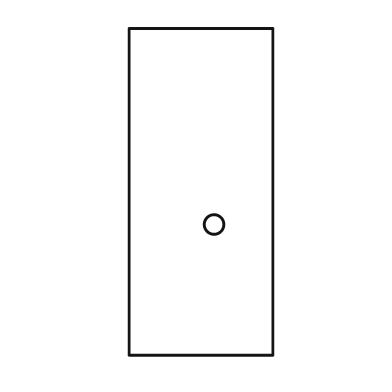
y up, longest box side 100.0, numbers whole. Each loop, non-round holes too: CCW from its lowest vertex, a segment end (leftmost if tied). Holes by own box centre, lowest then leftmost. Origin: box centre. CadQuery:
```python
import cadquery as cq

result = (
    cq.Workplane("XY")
    .moveTo(-22.0, -50.0)
    .lineTo(22.0, -50.0)
    .lineTo(22.0, 50.0)
    .lineTo(-22.0, 50.0)
    .close()
    .moveTo(4.0, -10.0)
    .circle(3.0)
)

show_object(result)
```